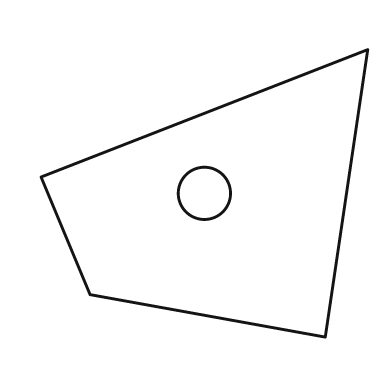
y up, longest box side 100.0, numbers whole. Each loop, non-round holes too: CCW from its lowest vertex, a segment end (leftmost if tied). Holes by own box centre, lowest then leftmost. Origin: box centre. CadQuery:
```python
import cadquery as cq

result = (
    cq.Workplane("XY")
    .moveTo(37.0, -44.0)
    .lineTo(50.0, 44.0)
    .lineTo(-50.0, 5.0)
    .lineTo(-35.0, -31.0)
    .close()
    .moveTo(0.0, 0.0)
    .circle(8.0)
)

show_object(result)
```